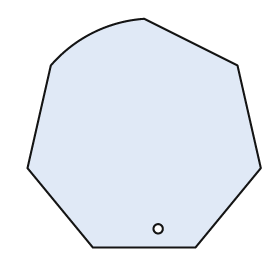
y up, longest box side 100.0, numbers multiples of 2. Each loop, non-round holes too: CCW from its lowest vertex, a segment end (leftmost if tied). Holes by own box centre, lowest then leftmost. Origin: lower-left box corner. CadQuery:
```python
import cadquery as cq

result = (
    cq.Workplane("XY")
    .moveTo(28.0, 0.0)
    .lineTo(72.0, 0.0)
    .lineTo(100.0, 34.0)
    .lineTo(90.0, 78.0)
    .lineTo(50.0, 98.0)
    .threePointArc((28.0, 92.0), (10.0, 78.0))
    .lineTo(0.0, 34.0)
    .close()
    .moveTo(56.0, 8.0)
    .circle(2.0)
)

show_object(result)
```